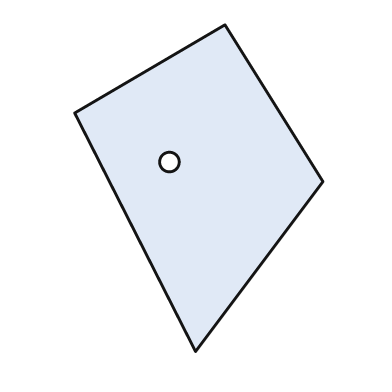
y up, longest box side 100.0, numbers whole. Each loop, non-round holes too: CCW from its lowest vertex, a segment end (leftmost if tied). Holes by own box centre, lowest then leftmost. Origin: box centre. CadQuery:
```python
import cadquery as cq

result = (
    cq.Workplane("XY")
    .moveTo(-1.0, -50.0)
    .lineTo(38.0, 2.0)
    .lineTo(8.0, 50.0)
    .lineTo(-38.0, 23.0)
    .close()
    .moveTo(-9.0, 8.0)
    .circle(3.0)
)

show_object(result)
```